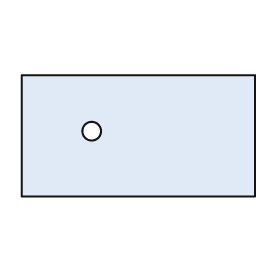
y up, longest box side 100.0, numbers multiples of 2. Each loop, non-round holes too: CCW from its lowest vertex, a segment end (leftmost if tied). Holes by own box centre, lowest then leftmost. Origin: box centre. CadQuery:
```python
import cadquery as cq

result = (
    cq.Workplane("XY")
    .moveTo(-50.0, -26.0)
    .lineTo(50.0, -26.0)
    .lineTo(50.0, 26.0)
    .lineTo(-50.0, 26.0)
    .close()
    .moveTo(-20.0, 2.0)
    .circle(4.0)
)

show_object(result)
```